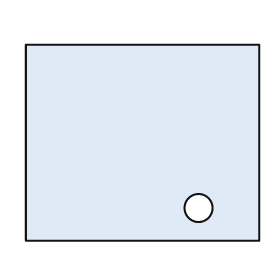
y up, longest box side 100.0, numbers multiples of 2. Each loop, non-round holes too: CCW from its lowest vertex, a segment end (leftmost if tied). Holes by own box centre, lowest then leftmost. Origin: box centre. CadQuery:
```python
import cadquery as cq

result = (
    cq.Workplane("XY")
    .moveTo(-50.0, -42.0)
    .lineTo(50.0, -42.0)
    .lineTo(50.0, 42.0)
    .lineTo(-50.0, 42.0)
    .close()
    .moveTo(24.0, -28.0)
    .circle(6.0)
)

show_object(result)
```